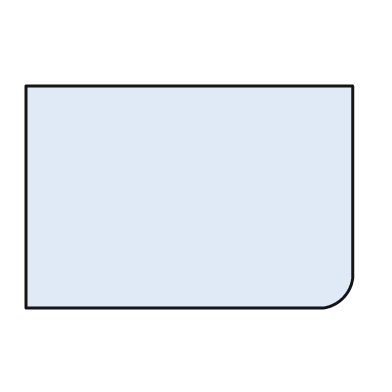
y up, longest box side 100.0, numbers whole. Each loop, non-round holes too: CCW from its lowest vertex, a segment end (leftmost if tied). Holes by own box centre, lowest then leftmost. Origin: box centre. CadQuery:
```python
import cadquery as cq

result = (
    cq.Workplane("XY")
    .moveTo(-50.0, -34.0)
    .lineTo(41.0, -34.0)
    .threePointArc((47.0, -31.0), (50.0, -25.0))
    .lineTo(50.0, 34.0)
    .lineTo(-50.0, 34.0)
    .close()
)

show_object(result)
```